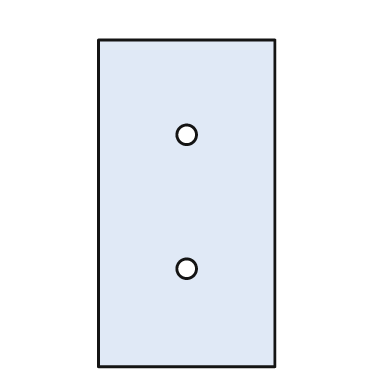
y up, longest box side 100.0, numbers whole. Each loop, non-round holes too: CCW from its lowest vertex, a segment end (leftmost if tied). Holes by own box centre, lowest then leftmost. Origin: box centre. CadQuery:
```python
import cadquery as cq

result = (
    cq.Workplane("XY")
    .moveTo(-27.0, -50.0)
    .lineTo(27.0, -50.0)
    .lineTo(27.0, 50.0)
    .lineTo(-27.0, 50.0)
    .close()
    .moveTo(0.0, -20.0)
    .circle(3.0)
    .moveTo(0.0, 21.0)
    .circle(3.0)
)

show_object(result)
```